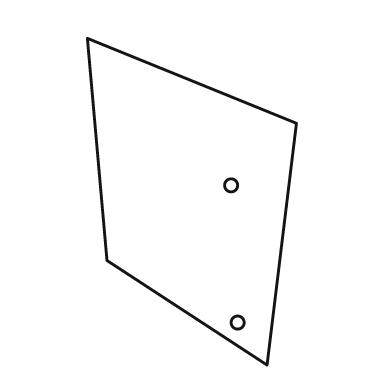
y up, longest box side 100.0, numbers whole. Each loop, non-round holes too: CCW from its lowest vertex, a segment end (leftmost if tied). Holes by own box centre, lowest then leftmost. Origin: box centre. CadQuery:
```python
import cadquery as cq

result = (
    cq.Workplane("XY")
    .moveTo(23.0, -50.0)
    .lineTo(32.0, 24.0)
    .lineTo(-32.0, 50.0)
    .lineTo(-26.0, -18.0)
    .close()
    .moveTo(14.0, -37.0)
    .circle(2.0)
    .moveTo(12.0, 5.0)
    .circle(2.0)
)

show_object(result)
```